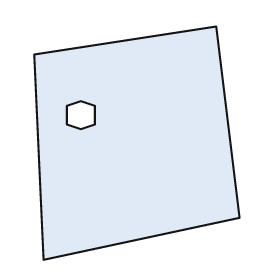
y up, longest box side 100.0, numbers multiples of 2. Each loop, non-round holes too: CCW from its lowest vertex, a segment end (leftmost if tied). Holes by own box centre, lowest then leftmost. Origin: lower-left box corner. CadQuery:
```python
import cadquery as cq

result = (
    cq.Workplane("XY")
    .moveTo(4.0, 0.0)
    .lineTo(88.0, 18.0)
    .lineTo(78.0, 100.0)
    .lineTo(0.0, 88.0)
    .close()
    .moveTo(20.0, 56.0)
    .lineTo(26.0, 58.0)
    .lineTo(26.0, 66.0)
    .lineTo(20.0, 68.0)
    .lineTo(14.0, 66.0)
    .lineTo(14.0, 58.0)
    .close()
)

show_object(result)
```